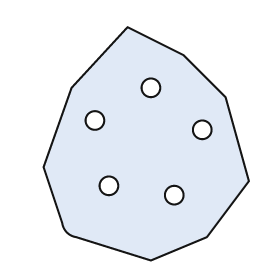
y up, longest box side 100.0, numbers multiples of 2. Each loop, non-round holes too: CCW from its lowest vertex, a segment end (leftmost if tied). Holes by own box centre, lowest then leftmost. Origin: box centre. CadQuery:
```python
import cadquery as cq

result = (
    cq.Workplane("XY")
    .moveTo(2.0, -50.0)
    .lineTo(26.0, -40.0)
    .lineTo(44.0, -16.0)
    .lineTo(34.0, 20.0)
    .lineTo(16.0, 38.0)
    .lineTo(-8.0, 50.0)
    .lineTo(-32.0, 24.0)
    .lineTo(-44.0, -10.0)
    .lineTo(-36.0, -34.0)
    .threePointArc((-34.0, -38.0), (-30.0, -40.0))
    .close()
    .moveTo(12.0, -22.0)
    .circle(4.0)
    .moveTo(-16.0, -18.0)
    .circle(4.0)
    .moveTo(24.0, 6.0)
    .circle(4.0)
    .moveTo(-22.0, 10.0)
    .circle(4.0)
    .moveTo(2.0, 24.0)
    .circle(4.0)
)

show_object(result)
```